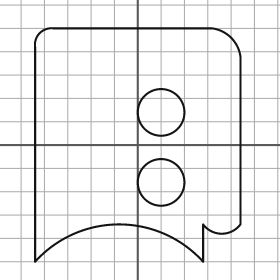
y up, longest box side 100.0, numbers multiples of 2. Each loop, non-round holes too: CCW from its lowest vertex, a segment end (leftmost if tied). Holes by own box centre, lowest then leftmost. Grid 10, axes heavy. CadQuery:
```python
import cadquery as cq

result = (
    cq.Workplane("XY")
    .moveTo(-44.0, -50.0)
    .threePointArc((-8.0, -34.0), (28.0, -50.0))
    .lineTo(28.0, -34.0)
    .threePointArc((36.0, -38.0), (44.0, -34.0))
    .lineTo(44.0, 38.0)
    .threePointArc((40.0, 46.0), (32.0, 50.0))
    .lineTo(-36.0, 50.0)
    .threePointArc((-42.0, 48.0), (-44.0, 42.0))
    .close()
    .moveTo(10.0, -16.0)
    .circle(10.0)
    .moveTo(10.0, 14.0)
    .circle(10.0)
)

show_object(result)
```